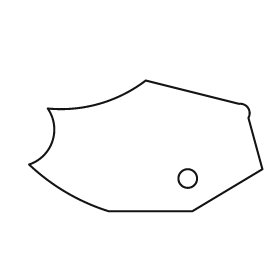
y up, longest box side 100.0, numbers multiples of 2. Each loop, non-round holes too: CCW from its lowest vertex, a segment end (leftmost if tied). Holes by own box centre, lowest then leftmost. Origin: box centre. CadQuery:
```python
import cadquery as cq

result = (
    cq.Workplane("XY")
    .moveTo(-16.0, -28.0)
    .lineTo(20.0, -28.0)
    .lineTo(50.0, -10.0)
    .lineTo(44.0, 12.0)
    .threePointArc((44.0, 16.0), (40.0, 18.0))
    .lineTo(0.0, 28.0)
    .threePointArc((-20.0, 18.0), (-42.0, 16.0))
    .threePointArc((-40.0, 2.0), (-50.0, -8.0))
    .threePointArc((-34.0, -20.0), (-16.0, -28.0))
    .close()
    .moveTo(18.0, -14.0)
    .circle(4.0)
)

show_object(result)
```